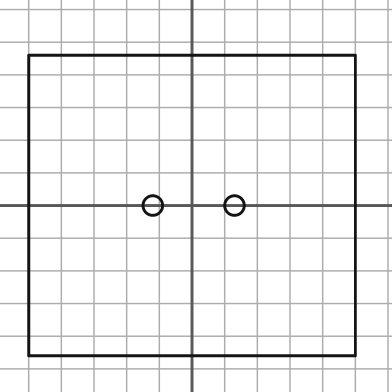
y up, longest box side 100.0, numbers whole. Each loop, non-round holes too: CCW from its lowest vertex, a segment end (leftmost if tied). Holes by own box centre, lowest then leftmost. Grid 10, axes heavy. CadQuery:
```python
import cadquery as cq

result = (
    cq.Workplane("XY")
    .moveTo(-50.0, -46.0)
    .lineTo(50.0, -46.0)
    .lineTo(50.0, 46.0)
    .lineTo(-50.0, 46.0)
    .close()
    .moveTo(-12.0, 0.0)
    .circle(3.0)
    .moveTo(13.0, 0.0)
    .circle(3.0)
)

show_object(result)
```